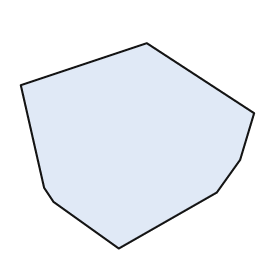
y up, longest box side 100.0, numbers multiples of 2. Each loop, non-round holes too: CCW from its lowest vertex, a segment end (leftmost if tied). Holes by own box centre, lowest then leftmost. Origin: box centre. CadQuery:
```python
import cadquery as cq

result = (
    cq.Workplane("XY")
    .moveTo(-8.0, -44.0)
    .lineTo(34.0, -20.0)
    .lineTo(44.0, -6.0)
    .lineTo(50.0, 14.0)
    .lineTo(4.0, 44.0)
    .lineTo(-50.0, 26.0)
    .lineTo(-40.0, -18.0)
    .lineTo(-36.0, -24.0)
    .close()
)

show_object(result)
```